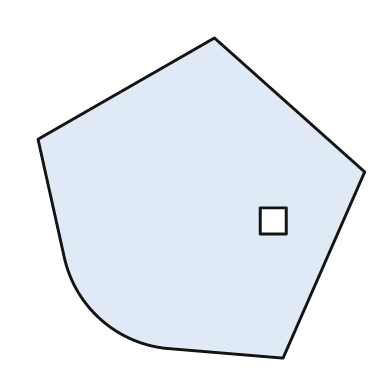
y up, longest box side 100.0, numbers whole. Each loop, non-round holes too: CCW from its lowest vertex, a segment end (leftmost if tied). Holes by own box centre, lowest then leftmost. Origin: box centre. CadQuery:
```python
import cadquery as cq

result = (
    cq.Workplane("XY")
    .moveTo(25.0, -49.0)
    .lineTo(50.0, 8.0)
    .lineTo(4.0, 49.0)
    .lineTo(-50.0, 18.0)
    .lineTo(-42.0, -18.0)
    .threePointArc((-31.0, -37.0), (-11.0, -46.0))
    .close()
    .moveTo(18.0, -11.0)
    .lineTo(26.0, -11.0)
    .lineTo(26.0, -3.0)
    .lineTo(18.0, -3.0)
    .close()
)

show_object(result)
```